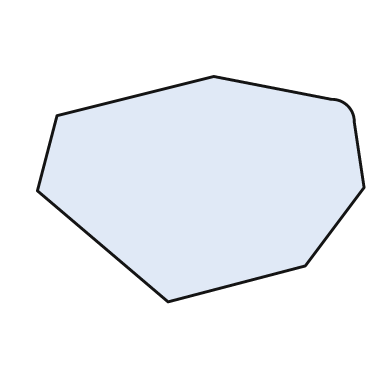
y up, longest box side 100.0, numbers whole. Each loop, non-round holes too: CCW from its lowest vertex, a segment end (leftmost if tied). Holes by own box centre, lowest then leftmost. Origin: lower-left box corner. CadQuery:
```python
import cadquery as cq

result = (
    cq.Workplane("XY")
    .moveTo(40.0, 0.0)
    .lineTo(82.0, 11.0)
    .lineTo(100.0, 35.0)
    .lineTo(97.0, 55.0)
    .threePointArc((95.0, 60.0), (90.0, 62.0))
    .lineTo(54.0, 69.0)
    .lineTo(6.0, 57.0)
    .lineTo(0.0, 34.0)
    .close()
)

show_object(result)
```